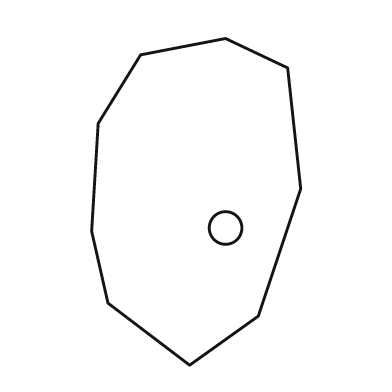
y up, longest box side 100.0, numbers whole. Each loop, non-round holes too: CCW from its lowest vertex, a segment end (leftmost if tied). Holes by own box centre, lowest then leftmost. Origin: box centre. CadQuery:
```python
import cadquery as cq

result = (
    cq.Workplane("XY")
    .moveTo(-2.0, -50.0)
    .lineTo(19.0, -35.0)
    .lineTo(32.0, 4.0)
    .lineTo(28.0, 41.0)
    .lineTo(9.0, 50.0)
    .lineTo(-17.0, 45.0)
    .lineTo(-30.0, 24.0)
    .lineTo(-32.0, -9.0)
    .lineTo(-27.0, -31.0)
    .close()
    .moveTo(9.0, -8.0)
    .circle(5.0)
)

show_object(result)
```